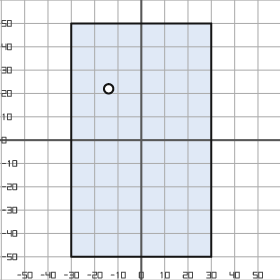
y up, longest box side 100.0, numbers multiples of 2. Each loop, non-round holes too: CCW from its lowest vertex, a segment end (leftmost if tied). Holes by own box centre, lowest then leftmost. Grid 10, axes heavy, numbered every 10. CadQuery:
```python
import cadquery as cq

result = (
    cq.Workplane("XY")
    .moveTo(-30.0, -50.0)
    .lineTo(30.0, -50.0)
    .lineTo(30.0, 50.0)
    .lineTo(-30.0, 50.0)
    .close()
    .moveTo(-14.0, 22.0)
    .circle(2.0)
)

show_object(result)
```